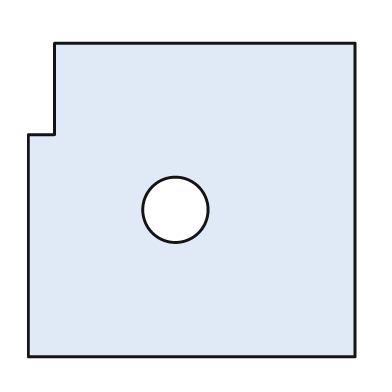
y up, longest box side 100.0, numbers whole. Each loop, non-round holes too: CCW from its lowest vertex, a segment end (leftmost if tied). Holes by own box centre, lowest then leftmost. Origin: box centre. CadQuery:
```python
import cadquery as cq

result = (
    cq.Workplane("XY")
    .moveTo(-50.0, -48.0)
    .lineTo(50.0, -48.0)
    .lineTo(50.0, 48.0)
    .lineTo(-42.0, 48.0)
    .lineTo(-42.0, 20.0)
    .lineTo(-50.0, 20.0)
    .close()
    .moveTo(-5.0, -3.0)
    .circle(10.0)
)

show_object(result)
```